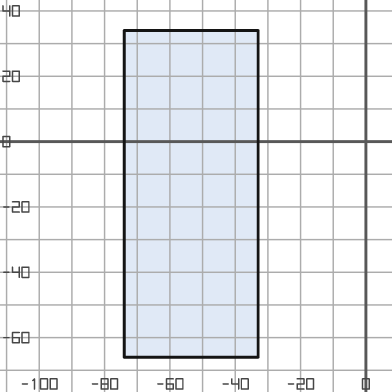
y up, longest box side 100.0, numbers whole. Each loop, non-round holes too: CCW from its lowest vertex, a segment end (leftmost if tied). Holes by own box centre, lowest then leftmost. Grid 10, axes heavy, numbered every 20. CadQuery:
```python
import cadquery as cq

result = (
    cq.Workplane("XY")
    .moveTo(-74.0, -66.0)
    .lineTo(-33.0, -66.0)
    .lineTo(-33.0, 34.0)
    .lineTo(-74.0, 34.0)
    .close()
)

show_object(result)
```